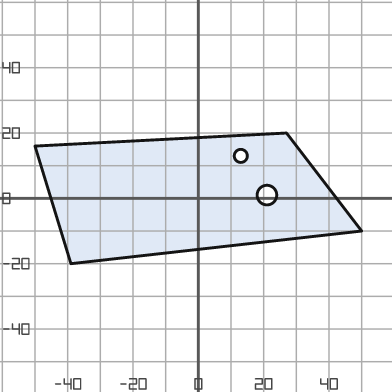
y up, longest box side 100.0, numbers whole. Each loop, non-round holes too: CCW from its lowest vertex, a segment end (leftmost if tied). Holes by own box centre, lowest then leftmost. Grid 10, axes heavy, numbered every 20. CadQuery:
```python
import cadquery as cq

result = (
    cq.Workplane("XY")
    .moveTo(-39.0, -20.0)
    .lineTo(50.0, -10.0)
    .lineTo(27.0, 20.0)
    .lineTo(-50.0, 16.0)
    .close()
    .moveTo(21.0, 1.0)
    .circle(3.0)
    .moveTo(13.0, 13.0)
    .circle(2.0)
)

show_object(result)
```